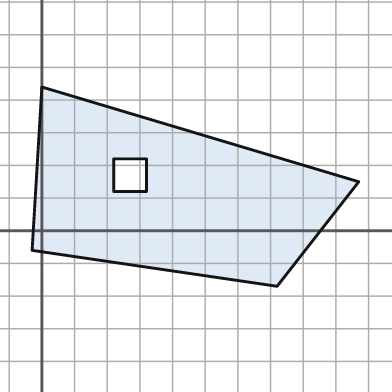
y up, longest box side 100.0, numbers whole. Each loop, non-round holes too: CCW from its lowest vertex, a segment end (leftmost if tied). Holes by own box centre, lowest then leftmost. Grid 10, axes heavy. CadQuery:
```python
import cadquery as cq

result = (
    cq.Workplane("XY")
    .moveTo(72.0, -17.0)
    .lineTo(97.0, 15.0)
    .lineTo(0.0, 44.0)
    .lineTo(-3.0, -6.0)
    .close()
    .moveTo(22.0, 12.0)
    .lineTo(32.0, 12.0)
    .lineTo(32.0, 22.0)
    .lineTo(22.0, 22.0)
    .close()
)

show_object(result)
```